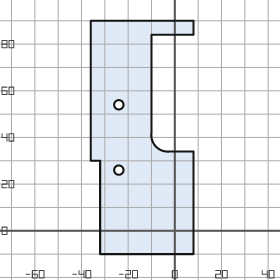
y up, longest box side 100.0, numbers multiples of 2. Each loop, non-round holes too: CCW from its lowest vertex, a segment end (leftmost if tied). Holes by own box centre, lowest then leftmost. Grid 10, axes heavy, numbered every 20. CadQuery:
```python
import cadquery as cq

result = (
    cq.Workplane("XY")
    .moveTo(-32.0, -10.0)
    .lineTo(8.0, -10.0)
    .lineTo(8.0, 34.0)
    .lineTo(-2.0, 34.0)
    .threePointArc((-8.0, 36.0), (-10.0, 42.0))
    .lineTo(-10.0, 84.0)
    .lineTo(8.0, 84.0)
    .lineTo(8.0, 90.0)
    .lineTo(-36.0, 90.0)
    .lineTo(-36.0, 30.0)
    .lineTo(-32.0, 30.0)
    .close()
    .moveTo(-24.0, 26.0)
    .circle(2.0)
    .moveTo(-24.0, 54.0)
    .circle(2.0)
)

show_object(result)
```